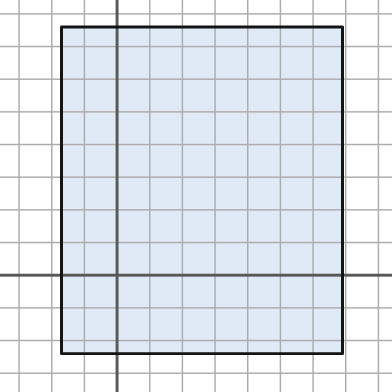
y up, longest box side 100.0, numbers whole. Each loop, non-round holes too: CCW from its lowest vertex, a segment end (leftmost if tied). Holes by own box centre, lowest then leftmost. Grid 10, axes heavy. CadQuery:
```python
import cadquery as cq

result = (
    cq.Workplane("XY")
    .moveTo(-17.0, -24.0)
    .lineTo(69.0, -24.0)
    .lineTo(69.0, 76.0)
    .lineTo(-17.0, 76.0)
    .close()
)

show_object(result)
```